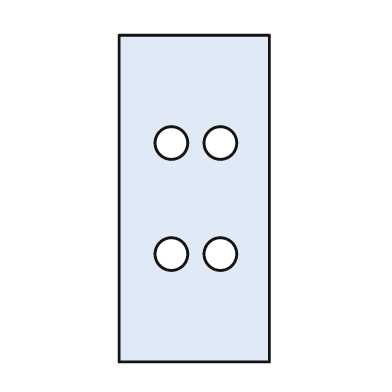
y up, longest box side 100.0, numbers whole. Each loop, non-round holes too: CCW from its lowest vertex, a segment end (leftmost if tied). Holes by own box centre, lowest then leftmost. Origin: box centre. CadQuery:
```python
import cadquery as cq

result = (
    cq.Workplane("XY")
    .moveTo(-23.0, -50.0)
    .lineTo(23.0, -50.0)
    .lineTo(23.0, 50.0)
    .lineTo(-23.0, 50.0)
    .close()
    .moveTo(-7.0, -17.0)
    .circle(5.0)
    .moveTo(8.0, -17.0)
    .circle(5.0)
    .moveTo(-7.0, 17.0)
    .circle(5.0)
    .moveTo(8.0, 17.0)
    .circle(5.0)
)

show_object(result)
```